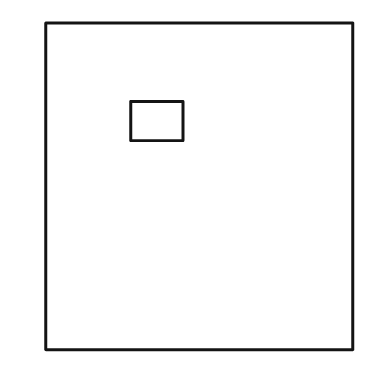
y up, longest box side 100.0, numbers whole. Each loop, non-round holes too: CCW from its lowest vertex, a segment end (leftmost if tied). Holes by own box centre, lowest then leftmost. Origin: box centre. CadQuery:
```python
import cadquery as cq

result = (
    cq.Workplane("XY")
    .moveTo(-47.0, -50.0)
    .lineTo(47.0, -50.0)
    .lineTo(47.0, 50.0)
    .lineTo(-47.0, 50.0)
    .close()
    .moveTo(-21.0, 14.0)
    .lineTo(-5.0, 14.0)
    .lineTo(-5.0, 26.0)
    .lineTo(-21.0, 26.0)
    .close()
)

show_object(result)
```